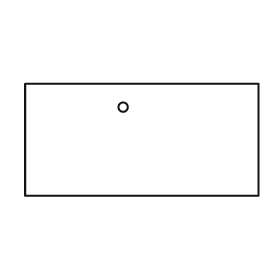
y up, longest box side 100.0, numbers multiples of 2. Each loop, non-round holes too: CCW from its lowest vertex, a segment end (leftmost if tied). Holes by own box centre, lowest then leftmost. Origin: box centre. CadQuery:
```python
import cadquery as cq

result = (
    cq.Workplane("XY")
    .moveTo(-50.0, -24.0)
    .lineTo(50.0, -24.0)
    .lineTo(50.0, 24.0)
    .lineTo(-50.0, 24.0)
    .close()
    .moveTo(-8.0, 14.0)
    .circle(2.0)
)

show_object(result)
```